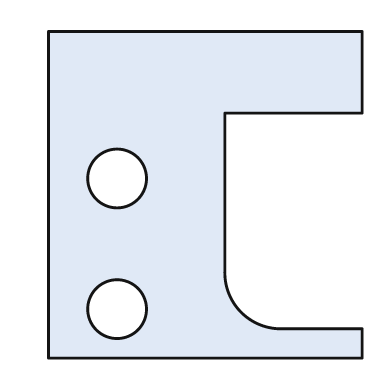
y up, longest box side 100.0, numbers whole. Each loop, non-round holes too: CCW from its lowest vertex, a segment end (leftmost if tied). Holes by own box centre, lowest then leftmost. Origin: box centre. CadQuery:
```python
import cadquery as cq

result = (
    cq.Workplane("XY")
    .moveTo(-48.0, -50.0)
    .lineTo(48.0, -50.0)
    .lineTo(48.0, -41.0)
    .lineTo(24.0, -41.0)
    .threePointArc((11.0, -36.0), (6.0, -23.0))
    .lineTo(6.0, 25.0)
    .lineTo(48.0, 25.0)
    .lineTo(48.0, 50.0)
    .lineTo(-48.0, 50.0)
    .close()
    .moveTo(-27.0, -35.0)
    .circle(9.0)
    .moveTo(-27.0, 5.0)
    .circle(9.0)
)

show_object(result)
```